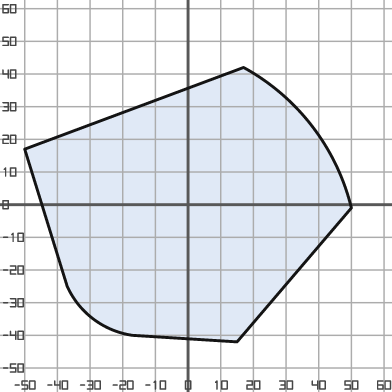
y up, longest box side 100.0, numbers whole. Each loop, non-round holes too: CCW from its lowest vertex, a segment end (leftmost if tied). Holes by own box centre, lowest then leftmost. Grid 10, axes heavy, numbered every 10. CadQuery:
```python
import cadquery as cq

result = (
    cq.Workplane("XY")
    .moveTo(15.0, -42.0)
    .lineTo(50.0, -1.0)
    .threePointArc((38.0, 24.0), (17.0, 42.0))
    .lineTo(-50.0, 17.0)
    .lineTo(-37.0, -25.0)
    .threePointArc((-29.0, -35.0), (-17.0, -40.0))
    .close()
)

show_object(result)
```